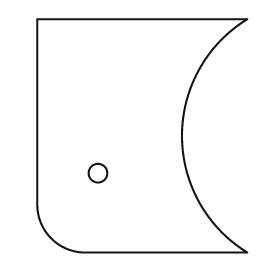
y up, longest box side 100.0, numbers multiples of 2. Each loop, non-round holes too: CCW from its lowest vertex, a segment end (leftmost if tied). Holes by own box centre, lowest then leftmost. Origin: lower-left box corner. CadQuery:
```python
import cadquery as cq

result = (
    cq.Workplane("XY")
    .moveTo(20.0, 0.0)
    .lineTo(90.0, 0.0)
    .threePointArc((62.0, 50.0), (90.0, 100.0))
    .lineTo(0.0, 100.0)
    .lineTo(0.0, 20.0)
    .threePointArc((6.0, 6.0), (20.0, 0.0))
    .close()
    .moveTo(26.0, 34.0)
    .circle(4.0)
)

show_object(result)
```